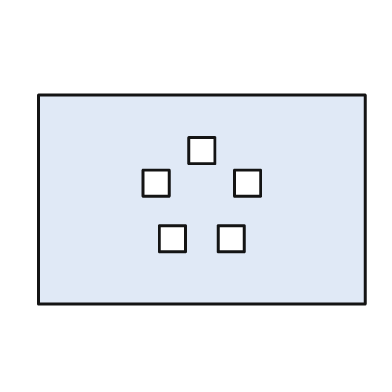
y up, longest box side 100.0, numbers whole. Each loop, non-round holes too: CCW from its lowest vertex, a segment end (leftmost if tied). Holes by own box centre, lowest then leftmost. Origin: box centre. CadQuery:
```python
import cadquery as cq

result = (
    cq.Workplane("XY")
    .moveTo(-50.0, -32.0)
    .lineTo(50.0, -32.0)
    .lineTo(50.0, 32.0)
    .lineTo(-50.0, 32.0)
    .close()
    .moveTo(-13.0, -16.0)
    .lineTo(-5.0, -16.0)
    .lineTo(-5.0, -8.0)
    .lineTo(-13.0, -8.0)
    .close()
    .moveTo(5.0, -16.0)
    .lineTo(13.0, -16.0)
    .lineTo(13.0, -8.0)
    .lineTo(5.0, -8.0)
    .close()
    .moveTo(-18.0, 1.0)
    .lineTo(-10.0, 1.0)
    .lineTo(-10.0, 9.0)
    .lineTo(-18.0, 9.0)
    .close()
    .moveTo(10.0, 1.0)
    .lineTo(18.0, 1.0)
    .lineTo(18.0, 9.0)
    .lineTo(10.0, 9.0)
    .close()
    .moveTo(-4.0, 11.0)
    .lineTo(4.0, 11.0)
    .lineTo(4.0, 19.0)
    .lineTo(-4.0, 19.0)
    .close()
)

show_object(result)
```